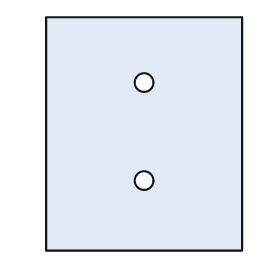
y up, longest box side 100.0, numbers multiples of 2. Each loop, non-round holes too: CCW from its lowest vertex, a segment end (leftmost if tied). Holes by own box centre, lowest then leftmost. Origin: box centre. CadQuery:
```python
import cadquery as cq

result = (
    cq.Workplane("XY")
    .moveTo(-42.0, -50.0)
    .lineTo(42.0, -50.0)
    .lineTo(42.0, 50.0)
    .lineTo(-42.0, 50.0)
    .close()
    .moveTo(0.0, -20.0)
    .circle(4.0)
    .moveTo(0.0, 22.0)
    .circle(4.0)
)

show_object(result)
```